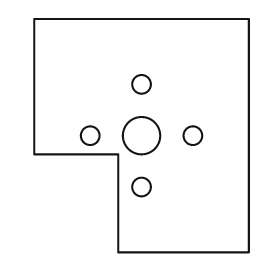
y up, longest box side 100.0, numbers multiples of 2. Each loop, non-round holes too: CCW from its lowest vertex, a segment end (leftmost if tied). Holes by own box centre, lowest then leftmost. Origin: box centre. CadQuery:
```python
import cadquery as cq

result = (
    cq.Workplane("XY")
    .moveTo(-10.0, -50.0)
    .lineTo(46.0, -50.0)
    .lineTo(46.0, 50.0)
    .lineTo(-46.0, 50.0)
    .lineTo(-46.0, -8.0)
    .lineTo(-10.0, -8.0)
    .close()
    .moveTo(0.0, -22.0)
    .circle(4.0)
    .moveTo(-22.0, 0.0)
    .circle(4.0)
    .moveTo(0.0, 0.0)
    .circle(8.0)
    .moveTo(22.0, 0.0)
    .circle(4.0)
    .moveTo(0.0, 22.0)
    .circle(4.0)
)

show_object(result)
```